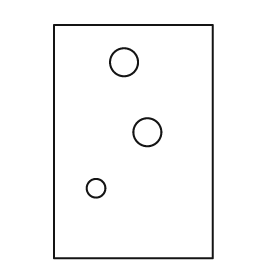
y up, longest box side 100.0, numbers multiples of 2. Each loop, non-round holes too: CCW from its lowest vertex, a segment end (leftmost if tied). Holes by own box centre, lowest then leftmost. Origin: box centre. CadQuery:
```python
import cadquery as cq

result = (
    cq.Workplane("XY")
    .moveTo(-34.0, -50.0)
    .lineTo(34.0, -50.0)
    .lineTo(34.0, 50.0)
    .lineTo(-34.0, 50.0)
    .close()
    .moveTo(-16.0, -20.0)
    .circle(4.0)
    .moveTo(6.0, 4.0)
    .circle(6.0)
    .moveTo(-4.0, 34.0)
    .circle(6.0)
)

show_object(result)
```